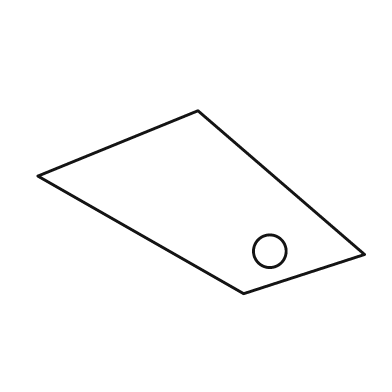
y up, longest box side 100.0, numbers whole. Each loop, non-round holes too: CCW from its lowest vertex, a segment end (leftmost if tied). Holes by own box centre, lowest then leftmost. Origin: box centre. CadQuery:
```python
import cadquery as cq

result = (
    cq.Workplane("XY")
    .moveTo(13.0, -28.0)
    .lineTo(50.0, -16.0)
    .lineTo(-1.0, 28.0)
    .lineTo(-50.0, 8.0)
    .close()
    .moveTo(21.0, -15.0)
    .circle(5.0)
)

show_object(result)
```